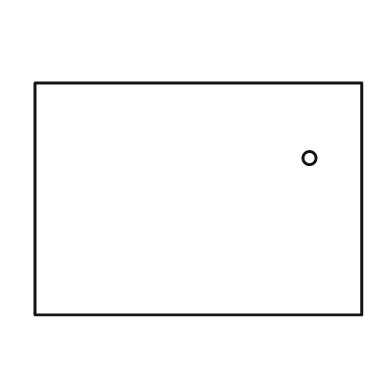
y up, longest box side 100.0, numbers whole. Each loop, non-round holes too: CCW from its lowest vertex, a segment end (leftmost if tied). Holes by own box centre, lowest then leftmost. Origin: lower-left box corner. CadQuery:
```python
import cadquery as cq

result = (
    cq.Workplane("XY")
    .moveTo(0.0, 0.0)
    .lineTo(100.0, 0.0)
    .lineTo(100.0, 71.0)
    .lineTo(0.0, 71.0)
    .close()
    .moveTo(84.0, 48.0)
    .circle(2.0)
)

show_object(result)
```